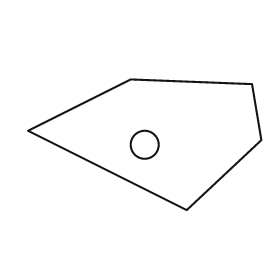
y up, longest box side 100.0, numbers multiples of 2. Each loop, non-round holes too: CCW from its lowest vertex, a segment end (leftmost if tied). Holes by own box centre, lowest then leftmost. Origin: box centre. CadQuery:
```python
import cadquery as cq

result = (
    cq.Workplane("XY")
    .moveTo(18.0, -28.0)
    .lineTo(50.0, 2.0)
    .lineTo(46.0, 26.0)
    .lineTo(-6.0, 28.0)
    .lineTo(-50.0, 6.0)
    .close()
    .moveTo(0.0, 0.0)
    .circle(6.0)
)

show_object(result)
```